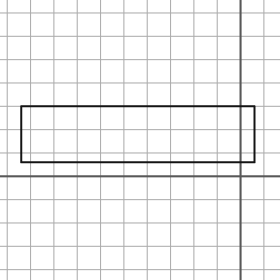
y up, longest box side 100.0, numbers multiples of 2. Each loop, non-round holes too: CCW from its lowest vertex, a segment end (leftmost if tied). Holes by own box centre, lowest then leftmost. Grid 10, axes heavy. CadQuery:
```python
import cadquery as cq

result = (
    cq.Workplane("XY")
    .moveTo(-94.0, 6.0)
    .lineTo(6.0, 6.0)
    .lineTo(6.0, 30.0)
    .lineTo(-94.0, 30.0)
    .close()
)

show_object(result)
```